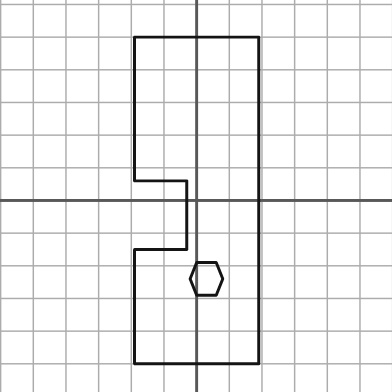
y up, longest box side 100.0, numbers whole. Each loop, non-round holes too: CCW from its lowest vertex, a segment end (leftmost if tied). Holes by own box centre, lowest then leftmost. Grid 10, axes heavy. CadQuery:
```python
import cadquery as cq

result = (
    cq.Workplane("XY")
    .moveTo(-19.0, -50.0)
    .lineTo(19.0, -50.0)
    .lineTo(19.0, 50.0)
    .lineTo(-19.0, 50.0)
    .lineTo(-19.0, 6.0)
    .lineTo(-3.0, 6.0)
    .lineTo(-3.0, -15.0)
    .lineTo(-19.0, -15.0)
    .close()
    .moveTo(0.0, -29.0)
    .lineTo(6.0, -29.0)
    .lineTo(8.0, -24.0)
    .lineTo(6.0, -19.0)
    .lineTo(0.0, -19.0)
    .lineTo(-2.0, -24.0)
    .close()
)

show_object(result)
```